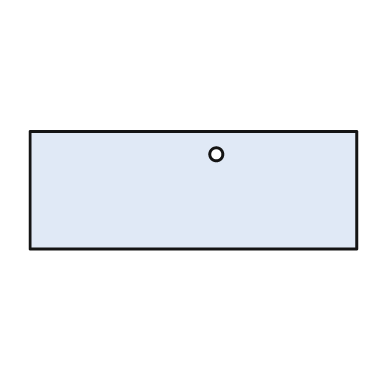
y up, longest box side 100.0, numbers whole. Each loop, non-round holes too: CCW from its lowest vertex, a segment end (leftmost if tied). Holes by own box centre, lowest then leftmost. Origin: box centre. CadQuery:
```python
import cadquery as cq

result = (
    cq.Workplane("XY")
    .moveTo(-50.0, -18.0)
    .lineTo(50.0, -18.0)
    .lineTo(50.0, 18.0)
    .lineTo(-50.0, 18.0)
    .close()
    .moveTo(7.0, 11.0)
    .circle(2.0)
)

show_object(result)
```